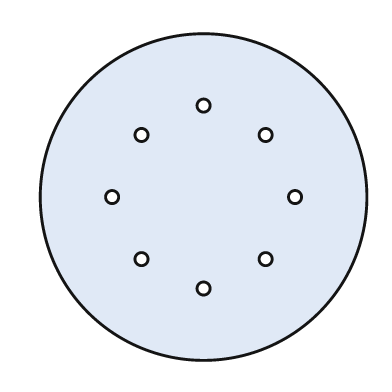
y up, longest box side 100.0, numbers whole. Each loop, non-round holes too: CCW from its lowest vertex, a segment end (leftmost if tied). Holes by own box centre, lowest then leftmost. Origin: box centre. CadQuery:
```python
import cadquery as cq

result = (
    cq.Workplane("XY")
    .moveTo(0.0, 0.0)
    .circle(50.0)
    .moveTo(0.0, -28.0)
    .circle(2.0)
    .moveTo(-19.0, -19.0)
    .circle(2.0)
    .moveTo(19.0, -19.0)
    .circle(2.0)
    .moveTo(-28.0, 0.0)
    .circle(2.0)
    .moveTo(28.0, 0.0)
    .circle(2.0)
    .moveTo(-19.0, 19.0)
    .circle(2.0)
    .moveTo(19.0, 19.0)
    .circle(2.0)
    .moveTo(0.0, 28.0)
    .circle(2.0)
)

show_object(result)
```